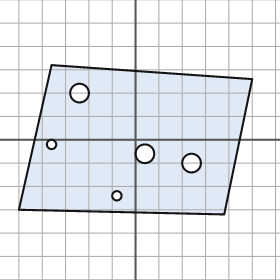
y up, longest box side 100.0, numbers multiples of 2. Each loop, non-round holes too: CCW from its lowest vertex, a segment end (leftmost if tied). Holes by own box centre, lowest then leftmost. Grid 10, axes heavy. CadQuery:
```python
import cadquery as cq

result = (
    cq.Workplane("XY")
    .moveTo(38.0, -32.0)
    .lineTo(50.0, 26.0)
    .lineTo(-36.0, 32.0)
    .lineTo(-50.0, -30.0)
    .close()
    .moveTo(-8.0, -24.0)
    .circle(2.0)
    .moveTo(24.0, -10.0)
    .circle(4.0)
    .moveTo(4.0, -6.0)
    .circle(4.0)
    .moveTo(-36.0, -2.0)
    .circle(2.0)
    .moveTo(-24.0, 20.0)
    .circle(4.0)
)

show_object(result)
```